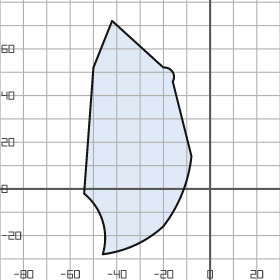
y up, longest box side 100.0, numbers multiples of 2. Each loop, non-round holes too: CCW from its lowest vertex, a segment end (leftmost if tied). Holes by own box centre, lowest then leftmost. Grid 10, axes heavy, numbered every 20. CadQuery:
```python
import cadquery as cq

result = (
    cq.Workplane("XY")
    .moveTo(-46.0, -28.0)
    .threePointArc((-32.0, -24.0), (-20.0, -16.0))
    .threePointArc((-12.0, -2.0), (-8.0, 14.0))
    .lineTo(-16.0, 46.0)
    .threePointArc((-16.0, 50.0), (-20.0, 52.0))
    .lineTo(-42.0, 72.0)
    .lineTo(-50.0, 52.0)
    .lineTo(-54.0, -2.0)
    .threePointArc((-46.0, -14.0), (-46.0, -28.0))
    .close()
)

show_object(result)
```